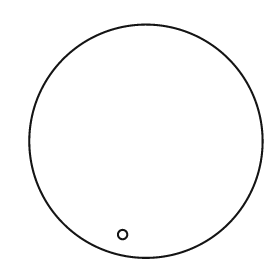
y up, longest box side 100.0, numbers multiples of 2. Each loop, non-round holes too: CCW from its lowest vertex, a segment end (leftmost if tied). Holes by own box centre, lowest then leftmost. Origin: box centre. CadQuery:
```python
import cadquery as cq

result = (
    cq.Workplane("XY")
    .moveTo(0.0, 0.0)
    .circle(50.0)
    .moveTo(-10.0, -40.0)
    .circle(2.0)
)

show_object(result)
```